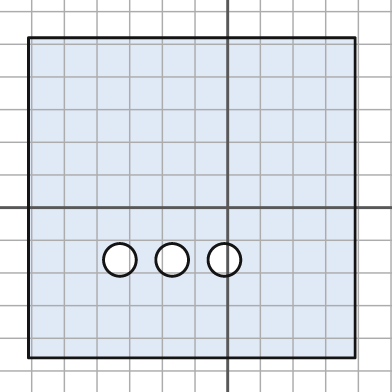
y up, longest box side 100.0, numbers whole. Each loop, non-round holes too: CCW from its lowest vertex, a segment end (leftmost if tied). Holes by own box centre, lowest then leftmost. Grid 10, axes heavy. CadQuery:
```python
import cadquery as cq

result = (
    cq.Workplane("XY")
    .moveTo(-61.0, -46.0)
    .lineTo(39.0, -46.0)
    .lineTo(39.0, 52.0)
    .lineTo(-61.0, 52.0)
    .close()
    .moveTo(-33.0, -16.0)
    .circle(5.0)
    .moveTo(-17.0, -16.0)
    .circle(5.0)
    .moveTo(-1.0, -16.0)
    .circle(5.0)
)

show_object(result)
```